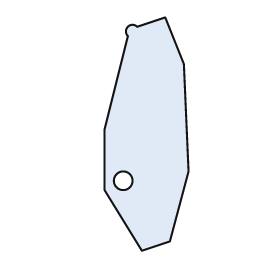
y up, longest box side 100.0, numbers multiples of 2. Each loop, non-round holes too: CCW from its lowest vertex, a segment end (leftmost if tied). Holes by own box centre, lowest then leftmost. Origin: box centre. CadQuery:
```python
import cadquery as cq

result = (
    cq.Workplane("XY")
    .moveTo(-2.0, -50.0)
    .lineTo(10.0, -46.0)
    .lineTo(18.0, -16.0)
    .lineTo(16.0, 30.0)
    .lineTo(8.0, 50.0)
    .lineTo(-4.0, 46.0)
    .threePointArc((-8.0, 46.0), (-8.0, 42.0))
    .lineTo(-18.0, 2.0)
    .lineTo(-18.0, -24.0)
    .close()
    .moveTo(-10.0, -20.0)
    .circle(4.0)
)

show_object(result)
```